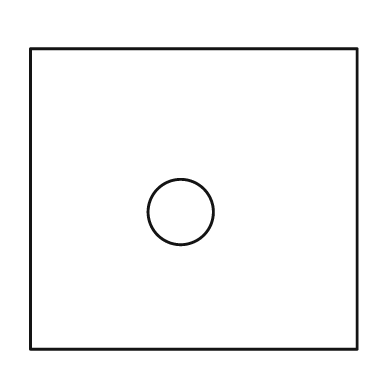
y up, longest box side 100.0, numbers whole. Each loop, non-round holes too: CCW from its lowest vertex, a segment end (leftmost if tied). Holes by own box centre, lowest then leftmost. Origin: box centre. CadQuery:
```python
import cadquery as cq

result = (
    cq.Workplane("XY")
    .moveTo(-50.0, -46.0)
    .lineTo(50.0, -46.0)
    .lineTo(50.0, 46.0)
    .lineTo(-50.0, 46.0)
    .close()
    .moveTo(-4.0, -4.0)
    .circle(10.0)
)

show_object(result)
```